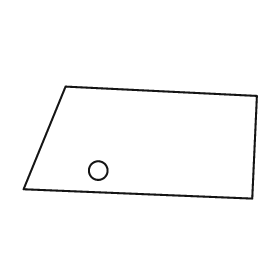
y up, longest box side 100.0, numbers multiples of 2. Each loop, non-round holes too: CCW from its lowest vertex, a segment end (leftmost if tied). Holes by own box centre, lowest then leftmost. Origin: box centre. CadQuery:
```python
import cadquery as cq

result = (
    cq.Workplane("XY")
    .moveTo(48.0, -24.0)
    .lineTo(50.0, 20.0)
    .lineTo(-32.0, 24.0)
    .lineTo(-50.0, -20.0)
    .close()
    .moveTo(-18.0, -12.0)
    .circle(4.0)
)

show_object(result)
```